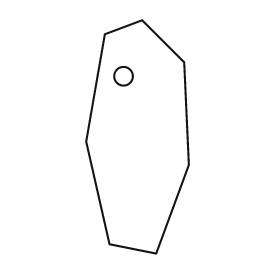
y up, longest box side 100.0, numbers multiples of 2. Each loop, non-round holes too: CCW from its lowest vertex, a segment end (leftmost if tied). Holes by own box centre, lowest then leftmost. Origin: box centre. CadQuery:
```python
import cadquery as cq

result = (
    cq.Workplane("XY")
    .moveTo(8.0, -50.0)
    .lineTo(22.0, -12.0)
    .lineTo(20.0, 32.0)
    .lineTo(2.0, 50.0)
    .lineTo(-14.0, 44.0)
    .lineTo(-22.0, -2.0)
    .lineTo(-12.0, -46.0)
    .close()
    .moveTo(-6.0, 26.0)
    .circle(4.0)
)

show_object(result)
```